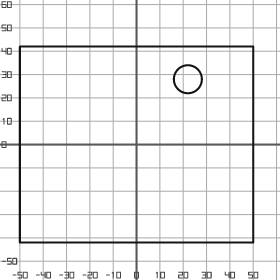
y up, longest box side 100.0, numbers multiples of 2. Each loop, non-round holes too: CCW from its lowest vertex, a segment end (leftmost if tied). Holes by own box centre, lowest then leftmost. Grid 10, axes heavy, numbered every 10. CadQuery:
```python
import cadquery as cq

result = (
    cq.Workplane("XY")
    .moveTo(-50.0, -42.0)
    .lineTo(50.0, -42.0)
    .lineTo(50.0, 42.0)
    .lineTo(-50.0, 42.0)
    .close()
    .moveTo(22.0, 28.0)
    .circle(6.0)
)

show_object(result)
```